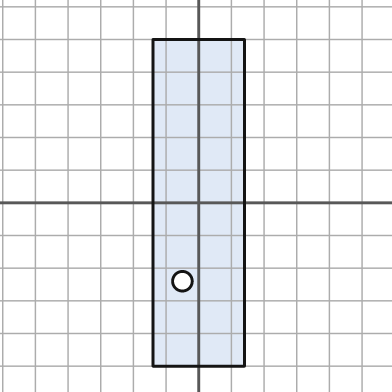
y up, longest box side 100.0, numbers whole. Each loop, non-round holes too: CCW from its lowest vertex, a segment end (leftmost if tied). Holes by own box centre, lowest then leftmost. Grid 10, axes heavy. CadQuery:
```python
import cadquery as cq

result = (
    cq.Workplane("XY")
    .moveTo(-14.0, -50.0)
    .lineTo(14.0, -50.0)
    .lineTo(14.0, 50.0)
    .lineTo(-14.0, 50.0)
    .close()
    .moveTo(-5.0, -24.0)
    .circle(3.0)
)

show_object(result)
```